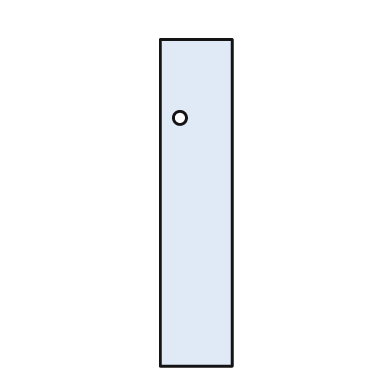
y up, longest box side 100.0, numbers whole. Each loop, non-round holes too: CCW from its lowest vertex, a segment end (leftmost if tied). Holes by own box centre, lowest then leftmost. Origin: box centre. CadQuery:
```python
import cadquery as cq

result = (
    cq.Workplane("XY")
    .moveTo(-11.0, -50.0)
    .lineTo(11.0, -50.0)
    .lineTo(11.0, 50.0)
    .lineTo(-11.0, 50.0)
    .close()
    .moveTo(-5.0, 26.0)
    .circle(2.0)
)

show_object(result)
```